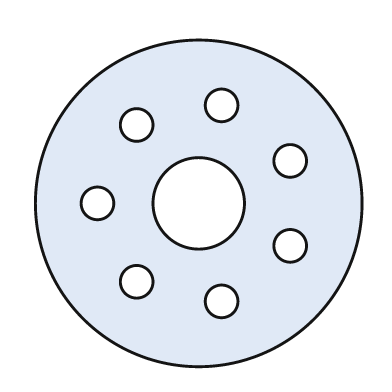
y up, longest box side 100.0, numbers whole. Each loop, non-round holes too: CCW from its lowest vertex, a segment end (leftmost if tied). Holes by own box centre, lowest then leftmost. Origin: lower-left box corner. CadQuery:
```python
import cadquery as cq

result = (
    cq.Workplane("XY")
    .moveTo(50.0, 50.0)
    .circle(50.0)
    .moveTo(57.0, 20.0)
    .circle(5.0)
    .moveTo(31.0, 26.0)
    .circle(5.0)
    .moveTo(78.0, 37.0)
    .circle(5.0)
    .moveTo(19.0, 50.0)
    .circle(5.0)
    .moveTo(50.0, 50.0)
    .circle(14.0)
    .moveTo(78.0, 63.0)
    .circle(5.0)
    .moveTo(31.0, 74.0)
    .circle(5.0)
    .moveTo(57.0, 80.0)
    .circle(5.0)
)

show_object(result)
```